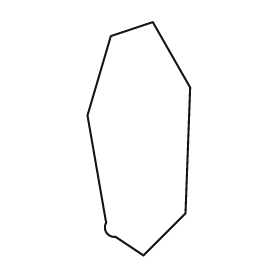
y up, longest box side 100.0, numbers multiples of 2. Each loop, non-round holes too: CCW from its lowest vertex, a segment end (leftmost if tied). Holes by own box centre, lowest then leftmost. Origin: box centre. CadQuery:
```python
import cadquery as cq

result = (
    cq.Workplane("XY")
    .moveTo(2.0, -50.0)
    .lineTo(20.0, -32.0)
    .lineTo(22.0, 22.0)
    .lineTo(6.0, 50.0)
    .lineTo(-12.0, 44.0)
    .lineTo(-22.0, 10.0)
    .lineTo(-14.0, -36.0)
    .threePointArc((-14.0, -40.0), (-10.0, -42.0))
    .close()
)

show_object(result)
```